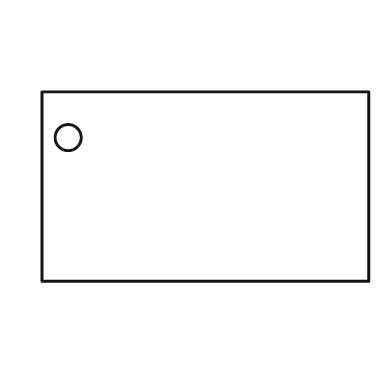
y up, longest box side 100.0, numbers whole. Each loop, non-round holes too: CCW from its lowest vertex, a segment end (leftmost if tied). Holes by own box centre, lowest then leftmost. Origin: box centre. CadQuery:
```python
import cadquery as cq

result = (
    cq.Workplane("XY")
    .moveTo(-50.0, -29.0)
    .lineTo(50.0, -29.0)
    .lineTo(50.0, 29.0)
    .lineTo(-50.0, 29.0)
    .close()
    .moveTo(-42.0, 15.0)
    .circle(4.0)
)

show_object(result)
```